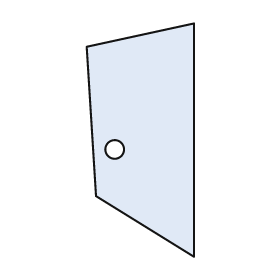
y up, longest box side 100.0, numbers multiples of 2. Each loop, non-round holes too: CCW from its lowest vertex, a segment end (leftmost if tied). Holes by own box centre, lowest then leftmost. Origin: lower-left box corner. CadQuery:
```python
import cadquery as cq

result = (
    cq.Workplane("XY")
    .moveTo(46.0, 0.0)
    .lineTo(46.0, 100.0)
    .lineTo(0.0, 90.0)
    .lineTo(4.0, 26.0)
    .close()
    .moveTo(12.0, 46.0)
    .circle(4.0)
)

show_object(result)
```